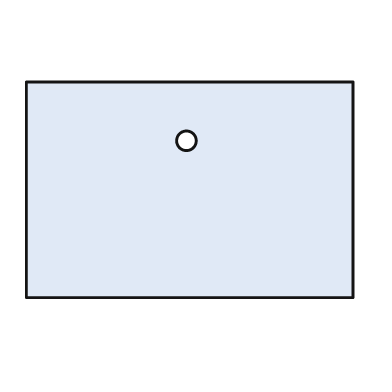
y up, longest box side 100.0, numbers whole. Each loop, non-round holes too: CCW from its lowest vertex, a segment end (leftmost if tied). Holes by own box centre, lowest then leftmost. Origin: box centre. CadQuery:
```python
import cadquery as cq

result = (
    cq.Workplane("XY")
    .moveTo(-50.0, -33.0)
    .lineTo(50.0, -33.0)
    .lineTo(50.0, 33.0)
    .lineTo(-50.0, 33.0)
    .close()
    .moveTo(-1.0, 15.0)
    .circle(3.0)
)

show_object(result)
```